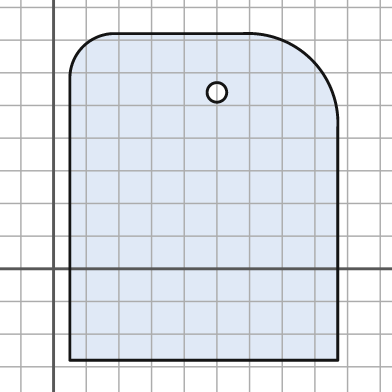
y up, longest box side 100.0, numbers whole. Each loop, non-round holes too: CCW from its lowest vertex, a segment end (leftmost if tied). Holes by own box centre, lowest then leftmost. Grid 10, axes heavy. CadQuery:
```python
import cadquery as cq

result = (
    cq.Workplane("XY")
    .moveTo(5.0, -28.0)
    .lineTo(87.0, -28.0)
    .lineTo(87.0, 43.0)
    .threePointArc((79.0, 64.0), (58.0, 72.0))
    .lineTo(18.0, 72.0)
    .threePointArc((9.0, 68.0), (5.0, 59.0))
    .close()
    .moveTo(50.0, 54.0)
    .circle(3.0)
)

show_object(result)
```